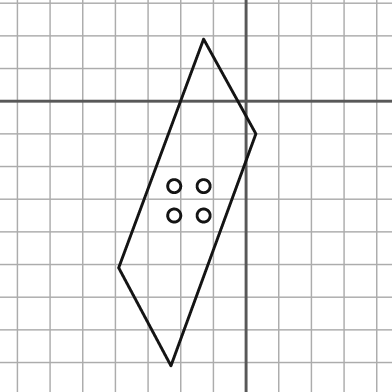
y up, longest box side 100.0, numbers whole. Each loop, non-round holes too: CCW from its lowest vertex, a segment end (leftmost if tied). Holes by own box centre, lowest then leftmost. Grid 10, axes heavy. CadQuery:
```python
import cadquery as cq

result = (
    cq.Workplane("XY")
    .moveTo(-23.0, -81.0)
    .lineTo(3.0, -10.0)
    .lineTo(-13.0, 19.0)
    .lineTo(-39.0, -51.0)
    .close()
    .moveTo(-22.0, -35.0)
    .circle(2.0)
    .moveTo(-13.0, -35.0)
    .circle(2.0)
    .moveTo(-22.0, -26.0)
    .circle(2.0)
    .moveTo(-13.0, -26.0)
    .circle(2.0)
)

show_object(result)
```